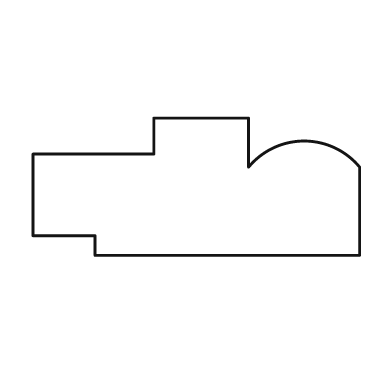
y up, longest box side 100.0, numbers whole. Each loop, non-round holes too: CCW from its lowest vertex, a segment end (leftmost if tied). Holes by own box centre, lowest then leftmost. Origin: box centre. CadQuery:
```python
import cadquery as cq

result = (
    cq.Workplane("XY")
    .moveTo(-31.0, -21.0)
    .lineTo(50.0, -21.0)
    .lineTo(50.0, 6.0)
    .threePointArc((33.0, 14.0), (16.0, 6.0))
    .lineTo(16.0, 21.0)
    .lineTo(-13.0, 21.0)
    .lineTo(-13.0, 10.0)
    .lineTo(-50.0, 10.0)
    .lineTo(-50.0, -15.0)
    .lineTo(-31.0, -15.0)
    .close()
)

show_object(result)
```